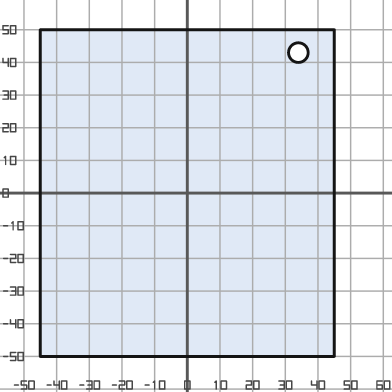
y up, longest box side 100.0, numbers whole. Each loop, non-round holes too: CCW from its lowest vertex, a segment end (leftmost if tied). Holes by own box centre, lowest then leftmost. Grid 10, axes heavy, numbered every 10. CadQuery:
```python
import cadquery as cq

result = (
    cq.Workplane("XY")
    .moveTo(-45.0, -50.0)
    .lineTo(45.0, -50.0)
    .lineTo(45.0, 50.0)
    .lineTo(-45.0, 50.0)
    .close()
    .moveTo(34.0, 43.0)
    .circle(3.0)
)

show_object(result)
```